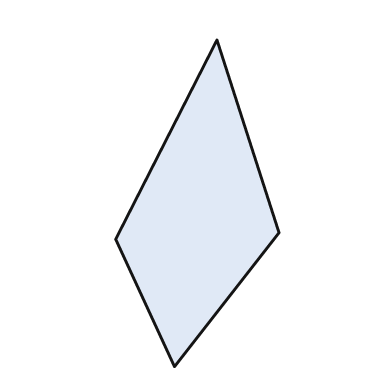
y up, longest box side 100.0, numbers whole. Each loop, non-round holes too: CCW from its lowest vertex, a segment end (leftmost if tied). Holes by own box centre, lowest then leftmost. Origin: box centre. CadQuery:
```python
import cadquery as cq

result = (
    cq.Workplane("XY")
    .moveTo(-7.0, -50.0)
    .lineTo(25.0, -9.0)
    .lineTo(6.0, 50.0)
    .lineTo(-25.0, -11.0)
    .close()
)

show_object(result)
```